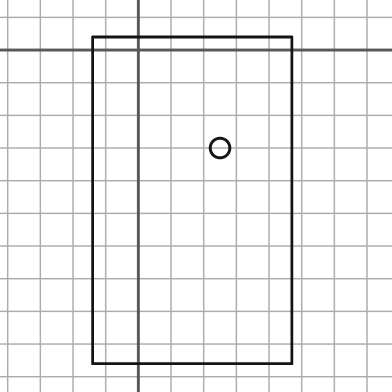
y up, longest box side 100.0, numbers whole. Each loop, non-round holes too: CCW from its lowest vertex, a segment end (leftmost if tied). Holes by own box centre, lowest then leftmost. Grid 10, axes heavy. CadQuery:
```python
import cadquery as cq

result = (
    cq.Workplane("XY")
    .moveTo(-14.0, -96.0)
    .lineTo(47.0, -96.0)
    .lineTo(47.0, 4.0)
    .lineTo(-14.0, 4.0)
    .close()
    .moveTo(25.0, -30.0)
    .circle(3.0)
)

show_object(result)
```